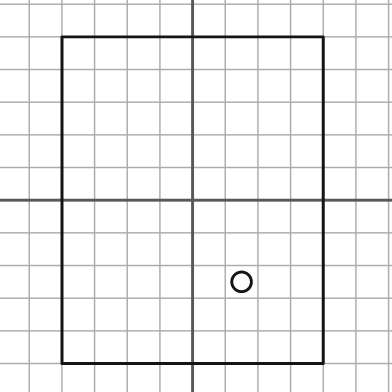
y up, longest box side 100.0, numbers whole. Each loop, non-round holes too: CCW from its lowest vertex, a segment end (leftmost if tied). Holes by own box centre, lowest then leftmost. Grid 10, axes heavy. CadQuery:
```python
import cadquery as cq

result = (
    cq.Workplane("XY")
    .moveTo(-40.0, -50.0)
    .lineTo(40.0, -50.0)
    .lineTo(40.0, 50.0)
    .lineTo(-40.0, 50.0)
    .close()
    .moveTo(15.0, -25.0)
    .circle(3.0)
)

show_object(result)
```